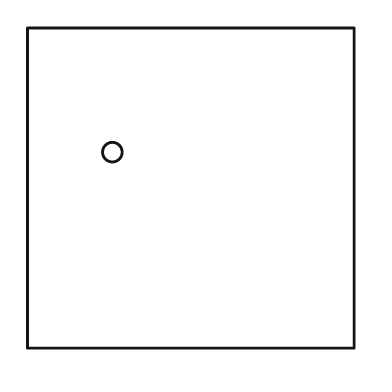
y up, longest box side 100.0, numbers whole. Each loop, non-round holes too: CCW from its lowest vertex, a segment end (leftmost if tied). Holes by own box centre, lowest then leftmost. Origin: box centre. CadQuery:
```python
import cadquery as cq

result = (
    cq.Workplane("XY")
    .moveTo(-50.0, -49.0)
    .lineTo(50.0, -49.0)
    .lineTo(50.0, 49.0)
    .lineTo(-50.0, 49.0)
    .close()
    .moveTo(-24.0, 11.0)
    .circle(3.0)
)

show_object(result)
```